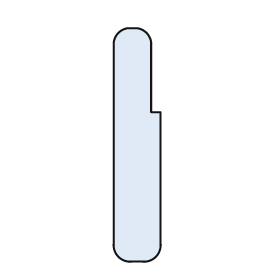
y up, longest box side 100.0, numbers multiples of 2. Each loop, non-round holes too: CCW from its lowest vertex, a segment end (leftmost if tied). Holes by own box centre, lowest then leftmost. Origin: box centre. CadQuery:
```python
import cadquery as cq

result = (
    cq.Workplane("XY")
    .moveTo(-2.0, -50.0)
    .lineTo(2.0, -50.0)
    .threePointArc((8.0, -48.0), (10.0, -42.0))
    .lineTo(10.0, 14.0)
    .lineTo(6.0, 14.0)
    .lineTo(6.0, 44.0)
    .threePointArc((4.0, 48.0), (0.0, 50.0))
    .lineTo(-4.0, 50.0)
    .threePointArc((-8.0, 48.0), (-10.0, 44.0))
    .lineTo(-10.0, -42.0)
    .threePointArc((-8.0, -48.0), (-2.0, -50.0))
    .close()
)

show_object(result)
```